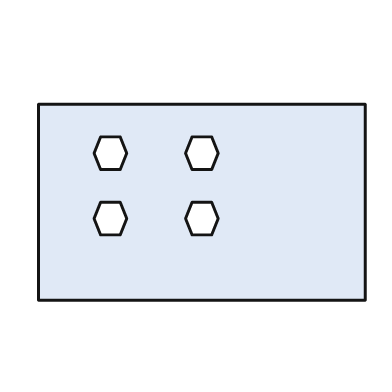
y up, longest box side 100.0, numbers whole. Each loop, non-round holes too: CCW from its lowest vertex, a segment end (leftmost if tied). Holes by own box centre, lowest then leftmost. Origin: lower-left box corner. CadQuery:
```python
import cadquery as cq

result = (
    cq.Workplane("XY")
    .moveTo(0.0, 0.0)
    .lineTo(100.0, 0.0)
    .lineTo(100.0, 60.0)
    .lineTo(0.0, 60.0)
    .close()
    .moveTo(19.0, 20.0)
    .lineTo(25.0, 20.0)
    .lineTo(27.0, 25.0)
    .lineTo(25.0, 30.0)
    .lineTo(19.0, 30.0)
    .lineTo(17.0, 25.0)
    .close()
    .moveTo(47.0, 20.0)
    .lineTo(53.0, 20.0)
    .lineTo(55.0, 25.0)
    .lineTo(53.0, 30.0)
    .lineTo(47.0, 30.0)
    .lineTo(45.0, 25.0)
    .close()
    .moveTo(19.0, 40.0)
    .lineTo(25.0, 40.0)
    .lineTo(27.0, 45.0)
    .lineTo(25.0, 50.0)
    .lineTo(19.0, 50.0)
    .lineTo(17.0, 45.0)
    .close()
    .moveTo(47.0, 40.0)
    .lineTo(53.0, 40.0)
    .lineTo(55.0, 45.0)
    .lineTo(53.0, 50.0)
    .lineTo(47.0, 50.0)
    .lineTo(45.0, 45.0)
    .close()
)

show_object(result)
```